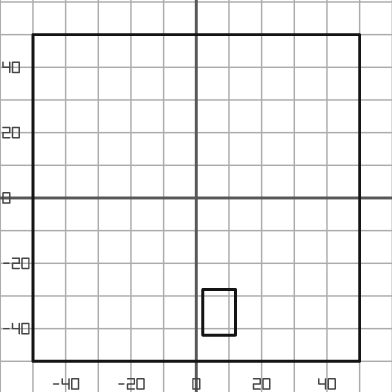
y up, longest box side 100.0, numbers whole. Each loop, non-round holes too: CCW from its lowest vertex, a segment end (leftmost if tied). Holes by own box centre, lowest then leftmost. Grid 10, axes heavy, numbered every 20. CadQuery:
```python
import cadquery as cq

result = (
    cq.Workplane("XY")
    .moveTo(-50.0, -50.0)
    .lineTo(50.0, -50.0)
    .lineTo(50.0, 50.0)
    .lineTo(-50.0, 50.0)
    .close()
    .moveTo(2.0, -42.0)
    .lineTo(12.0, -42.0)
    .lineTo(12.0, -28.0)
    .lineTo(2.0, -28.0)
    .close()
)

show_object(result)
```